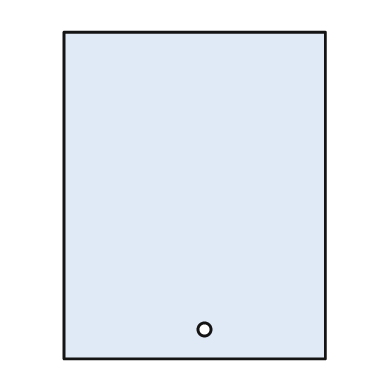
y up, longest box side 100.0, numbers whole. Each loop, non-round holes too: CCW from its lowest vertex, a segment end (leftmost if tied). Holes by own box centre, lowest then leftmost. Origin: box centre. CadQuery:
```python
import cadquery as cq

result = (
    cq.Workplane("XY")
    .moveTo(-40.0, -50.0)
    .lineTo(40.0, -50.0)
    .lineTo(40.0, 50.0)
    .lineTo(-40.0, 50.0)
    .close()
    .moveTo(3.0, -41.0)
    .circle(2.0)
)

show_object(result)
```